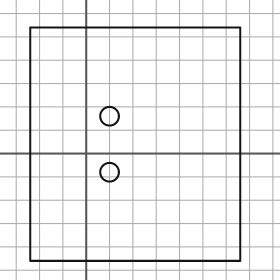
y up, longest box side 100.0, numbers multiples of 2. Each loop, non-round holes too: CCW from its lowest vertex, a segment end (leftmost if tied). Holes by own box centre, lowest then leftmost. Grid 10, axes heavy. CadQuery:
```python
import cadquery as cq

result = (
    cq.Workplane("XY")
    .moveTo(-24.0, -46.0)
    .lineTo(66.0, -46.0)
    .lineTo(66.0, 54.0)
    .lineTo(-24.0, 54.0)
    .close()
    .moveTo(10.0, -8.0)
    .circle(4.0)
    .moveTo(10.0, 16.0)
    .circle(4.0)
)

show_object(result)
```